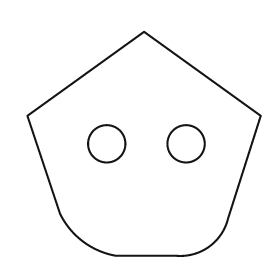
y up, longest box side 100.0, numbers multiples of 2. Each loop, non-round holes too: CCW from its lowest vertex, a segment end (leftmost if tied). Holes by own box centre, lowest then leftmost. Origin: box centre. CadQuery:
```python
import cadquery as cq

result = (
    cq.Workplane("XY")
    .moveTo(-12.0, -48.0)
    .lineTo(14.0, -48.0)
    .threePointArc((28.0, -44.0), (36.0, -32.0))
    .lineTo(50.0, 12.0)
    .lineTo(0.0, 48.0)
    .lineTo(-50.0, 12.0)
    .lineTo(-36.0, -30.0)
    .threePointArc((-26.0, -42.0), (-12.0, -48.0))
    .close()
    .moveTo(-16.0, 0.0)
    .circle(8.0)
    .moveTo(18.0, 0.0)
    .circle(8.0)
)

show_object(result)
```